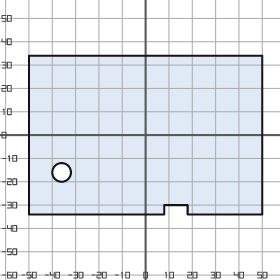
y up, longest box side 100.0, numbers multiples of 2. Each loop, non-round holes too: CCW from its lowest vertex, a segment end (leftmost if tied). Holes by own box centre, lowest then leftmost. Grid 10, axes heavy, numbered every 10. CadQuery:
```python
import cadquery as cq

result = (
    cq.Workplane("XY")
    .moveTo(-50.0, -34.0)
    .lineTo(8.0, -34.0)
    .lineTo(8.0, -30.0)
    .lineTo(18.0, -30.0)
    .lineTo(18.0, -34.0)
    .lineTo(50.0, -34.0)
    .lineTo(50.0, 34.0)
    .lineTo(-50.0, 34.0)
    .close()
    .moveTo(-36.0, -16.0)
    .circle(4.0)
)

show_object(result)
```